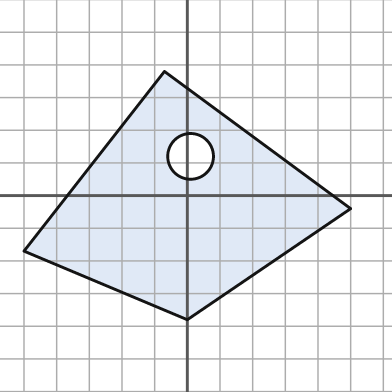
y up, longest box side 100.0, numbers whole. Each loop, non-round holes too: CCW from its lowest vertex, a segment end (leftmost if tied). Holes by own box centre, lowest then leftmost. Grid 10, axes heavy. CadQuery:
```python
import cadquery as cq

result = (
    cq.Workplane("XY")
    .moveTo(0.0, -38.0)
    .lineTo(50.0, -4.0)
    .lineTo(-7.0, 38.0)
    .lineTo(-50.0, -17.0)
    .close()
    .moveTo(1.0, 12.0)
    .circle(7.0)
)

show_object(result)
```